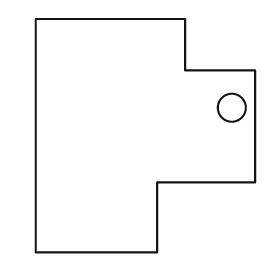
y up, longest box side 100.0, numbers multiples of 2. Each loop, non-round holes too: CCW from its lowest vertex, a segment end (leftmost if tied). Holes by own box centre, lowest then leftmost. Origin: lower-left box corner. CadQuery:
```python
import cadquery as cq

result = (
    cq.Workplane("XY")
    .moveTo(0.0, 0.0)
    .lineTo(52.0, 0.0)
    .lineTo(52.0, 30.0)
    .lineTo(94.0, 30.0)
    .lineTo(94.0, 78.0)
    .lineTo(64.0, 78.0)
    .lineTo(64.0, 100.0)
    .lineTo(0.0, 100.0)
    .close()
    .moveTo(84.0, 62.0)
    .circle(6.0)
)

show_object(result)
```